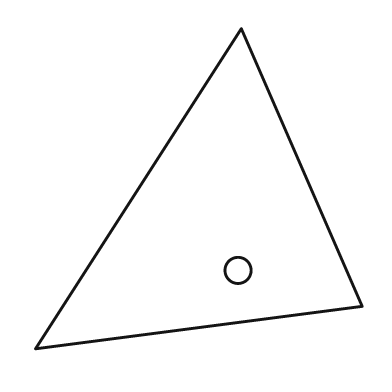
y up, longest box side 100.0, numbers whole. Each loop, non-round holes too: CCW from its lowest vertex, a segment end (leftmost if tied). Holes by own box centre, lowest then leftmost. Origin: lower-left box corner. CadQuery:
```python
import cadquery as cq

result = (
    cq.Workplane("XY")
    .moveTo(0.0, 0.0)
    .lineTo(100.0, 13.0)
    .lineTo(63.0, 98.0)
    .close()
    .moveTo(62.0, 24.0)
    .circle(4.0)
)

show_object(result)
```